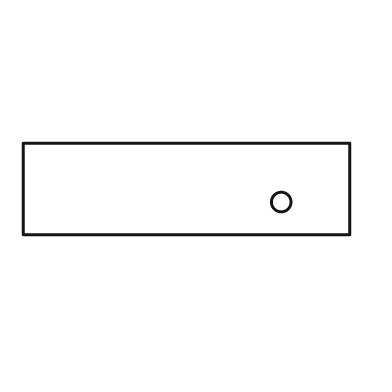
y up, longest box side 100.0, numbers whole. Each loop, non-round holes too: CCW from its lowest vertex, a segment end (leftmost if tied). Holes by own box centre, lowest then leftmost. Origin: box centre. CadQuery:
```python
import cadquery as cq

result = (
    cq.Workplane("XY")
    .moveTo(-50.0, -14.0)
    .lineTo(50.0, -14.0)
    .lineTo(50.0, 14.0)
    .lineTo(-50.0, 14.0)
    .close()
    .moveTo(29.0, -4.0)
    .circle(3.0)
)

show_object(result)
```